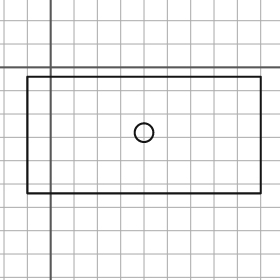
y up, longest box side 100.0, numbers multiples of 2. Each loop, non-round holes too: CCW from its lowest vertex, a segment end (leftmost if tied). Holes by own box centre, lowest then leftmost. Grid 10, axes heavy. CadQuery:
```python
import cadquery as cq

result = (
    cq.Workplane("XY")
    .moveTo(-10.0, -54.0)
    .lineTo(90.0, -54.0)
    .lineTo(90.0, -4.0)
    .lineTo(-10.0, -4.0)
    .close()
    .moveTo(40.0, -28.0)
    .circle(4.0)
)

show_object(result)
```